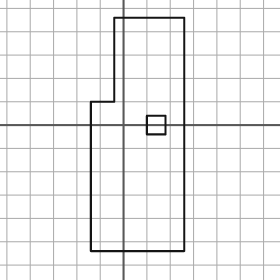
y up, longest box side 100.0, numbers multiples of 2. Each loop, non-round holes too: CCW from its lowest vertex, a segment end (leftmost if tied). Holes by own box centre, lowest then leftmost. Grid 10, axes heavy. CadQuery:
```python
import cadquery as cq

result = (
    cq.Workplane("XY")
    .moveTo(-14.0, -54.0)
    .lineTo(26.0, -54.0)
    .lineTo(26.0, 46.0)
    .lineTo(-4.0, 46.0)
    .lineTo(-4.0, 10.0)
    .lineTo(-14.0, 10.0)
    .close()
    .moveTo(10.0, -4.0)
    .lineTo(18.0, -4.0)
    .lineTo(18.0, 4.0)
    .lineTo(10.0, 4.0)
    .close()
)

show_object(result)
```